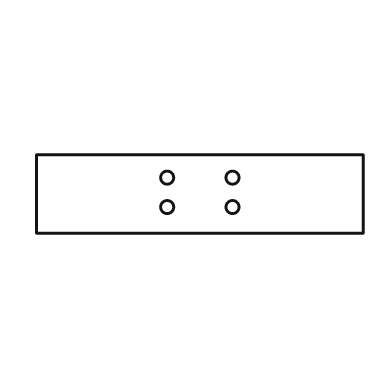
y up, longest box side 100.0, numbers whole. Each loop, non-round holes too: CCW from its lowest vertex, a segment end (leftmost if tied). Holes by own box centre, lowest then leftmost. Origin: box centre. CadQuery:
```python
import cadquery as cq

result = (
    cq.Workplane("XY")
    .moveTo(-50.0, -12.0)
    .lineTo(50.0, -12.0)
    .lineTo(50.0, 12.0)
    .lineTo(-50.0, 12.0)
    .close()
    .moveTo(-10.0, -4.0)
    .circle(2.0)
    .moveTo(10.0, -4.0)
    .circle(2.0)
    .moveTo(-10.0, 5.0)
    .circle(2.0)
    .moveTo(10.0, 5.0)
    .circle(2.0)
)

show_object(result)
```